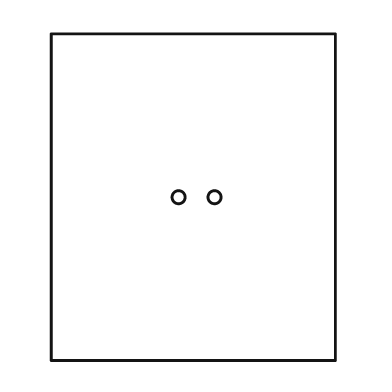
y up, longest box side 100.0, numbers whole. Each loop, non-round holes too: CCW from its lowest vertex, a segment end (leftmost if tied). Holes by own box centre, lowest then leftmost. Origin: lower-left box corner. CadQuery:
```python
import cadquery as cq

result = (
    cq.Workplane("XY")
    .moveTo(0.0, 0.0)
    .lineTo(87.0, 0.0)
    .lineTo(87.0, 100.0)
    .lineTo(0.0, 100.0)
    .close()
    .moveTo(39.0, 50.0)
    .circle(2.0)
    .moveTo(50.0, 50.0)
    .circle(2.0)
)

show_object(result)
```